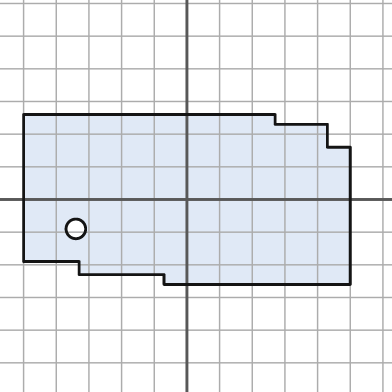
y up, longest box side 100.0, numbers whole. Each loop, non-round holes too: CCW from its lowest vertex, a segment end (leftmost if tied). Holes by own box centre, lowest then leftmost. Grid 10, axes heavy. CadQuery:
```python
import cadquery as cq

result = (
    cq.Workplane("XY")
    .moveTo(-7.0, -26.0)
    .lineTo(50.0, -26.0)
    .lineTo(50.0, 16.0)
    .lineTo(43.0, 16.0)
    .lineTo(43.0, 23.0)
    .lineTo(27.0, 23.0)
    .lineTo(27.0, 26.0)
    .lineTo(-50.0, 26.0)
    .lineTo(-50.0, -19.0)
    .lineTo(-33.0, -19.0)
    .lineTo(-33.0, -23.0)
    .lineTo(-7.0, -23.0)
    .close()
    .moveTo(-34.0, -9.0)
    .circle(3.0)
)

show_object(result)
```